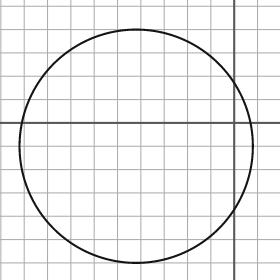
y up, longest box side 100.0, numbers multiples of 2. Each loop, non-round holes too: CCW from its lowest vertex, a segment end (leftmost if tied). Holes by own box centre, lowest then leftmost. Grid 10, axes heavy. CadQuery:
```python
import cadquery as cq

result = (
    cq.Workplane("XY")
    .moveTo(-42.0, -10.0)
    .circle(50.0)
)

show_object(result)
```